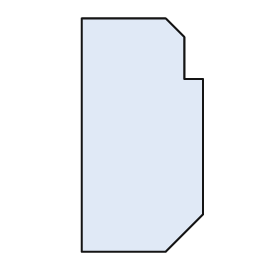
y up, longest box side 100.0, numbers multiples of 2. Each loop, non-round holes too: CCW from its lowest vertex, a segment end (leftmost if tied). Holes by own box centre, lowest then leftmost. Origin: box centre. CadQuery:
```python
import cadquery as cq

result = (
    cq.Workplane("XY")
    .moveTo(-26.0, -50.0)
    .lineTo(10.0, -50.0)
    .lineTo(26.0, -34.0)
    .lineTo(26.0, 24.0)
    .lineTo(18.0, 24.0)
    .lineTo(18.0, 42.0)
    .lineTo(10.0, 50.0)
    .lineTo(-26.0, 50.0)
    .close()
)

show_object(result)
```